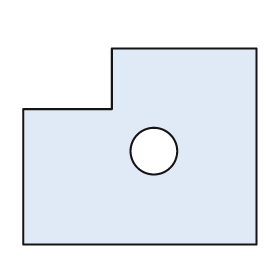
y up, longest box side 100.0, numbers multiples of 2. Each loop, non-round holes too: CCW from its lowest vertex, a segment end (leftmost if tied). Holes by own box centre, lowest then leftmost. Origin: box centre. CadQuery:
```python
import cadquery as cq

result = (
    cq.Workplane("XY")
    .moveTo(-50.0, -42.0)
    .lineTo(50.0, -42.0)
    .lineTo(50.0, 42.0)
    .lineTo(-12.0, 42.0)
    .lineTo(-12.0, 16.0)
    .lineTo(-50.0, 16.0)
    .close()
    .moveTo(6.0, -2.0)
    .circle(10.0)
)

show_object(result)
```